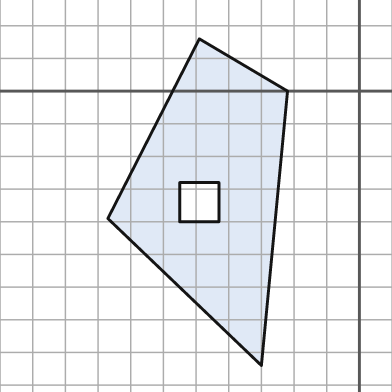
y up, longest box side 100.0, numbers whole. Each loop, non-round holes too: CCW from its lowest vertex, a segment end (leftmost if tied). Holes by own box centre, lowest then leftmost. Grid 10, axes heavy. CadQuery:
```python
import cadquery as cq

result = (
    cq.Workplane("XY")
    .moveTo(-30.0, -84.0)
    .lineTo(-22.0, 0.0)
    .lineTo(-49.0, 16.0)
    .lineTo(-77.0, -39.0)
    .close()
    .moveTo(-55.0, -40.0)
    .lineTo(-43.0, -40.0)
    .lineTo(-43.0, -28.0)
    .lineTo(-55.0, -28.0)
    .close()
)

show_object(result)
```